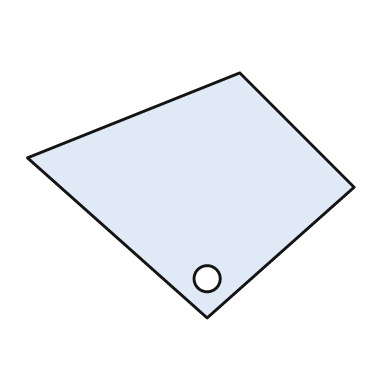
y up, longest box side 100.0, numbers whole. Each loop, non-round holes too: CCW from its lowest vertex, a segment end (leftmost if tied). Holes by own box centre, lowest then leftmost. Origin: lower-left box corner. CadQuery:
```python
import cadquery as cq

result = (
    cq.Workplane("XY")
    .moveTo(55.0, 0.0)
    .lineTo(100.0, 40.0)
    .lineTo(65.0, 75.0)
    .lineTo(0.0, 49.0)
    .close()
    .moveTo(55.0, 12.0)
    .circle(4.0)
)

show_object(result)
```